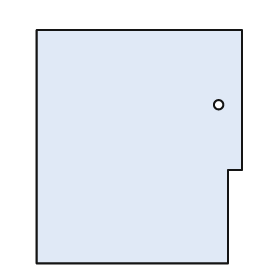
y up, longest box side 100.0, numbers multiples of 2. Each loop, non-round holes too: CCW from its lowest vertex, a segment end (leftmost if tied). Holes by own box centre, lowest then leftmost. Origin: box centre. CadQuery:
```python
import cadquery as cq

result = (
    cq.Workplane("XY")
    .moveTo(-44.0, -50.0)
    .lineTo(38.0, -50.0)
    .lineTo(38.0, -10.0)
    .lineTo(44.0, -10.0)
    .lineTo(44.0, 50.0)
    .lineTo(-44.0, 50.0)
    .close()
    .moveTo(34.0, 18.0)
    .circle(2.0)
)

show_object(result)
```